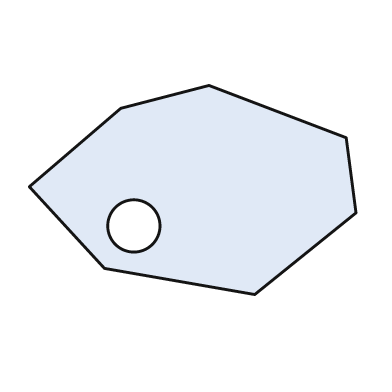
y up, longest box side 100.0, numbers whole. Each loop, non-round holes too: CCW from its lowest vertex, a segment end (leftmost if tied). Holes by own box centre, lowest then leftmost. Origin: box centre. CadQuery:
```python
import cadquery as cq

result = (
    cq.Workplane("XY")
    .moveTo(19.0, -32.0)
    .lineTo(50.0, -7.0)
    .lineTo(47.0, 16.0)
    .lineTo(5.0, 32.0)
    .lineTo(-22.0, 25.0)
    .lineTo(-50.0, 1.0)
    .lineTo(-27.0, -24.0)
    .close()
    .moveTo(-18.0, -11.0)
    .circle(8.0)
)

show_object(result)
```